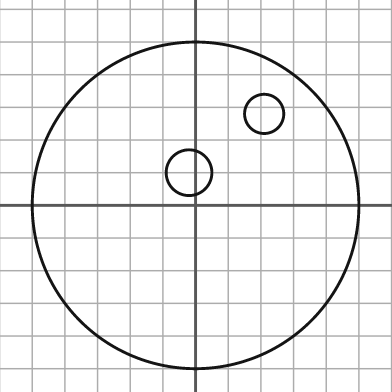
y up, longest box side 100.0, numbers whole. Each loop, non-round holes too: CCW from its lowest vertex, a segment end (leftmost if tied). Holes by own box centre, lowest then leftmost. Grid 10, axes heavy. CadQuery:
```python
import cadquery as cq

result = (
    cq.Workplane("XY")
    .moveTo(0.0, 0.0)
    .circle(50.0)
    .moveTo(-2.0, 10.0)
    .circle(7.0)
    .moveTo(21.0, 28.0)
    .circle(6.0)
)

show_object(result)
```